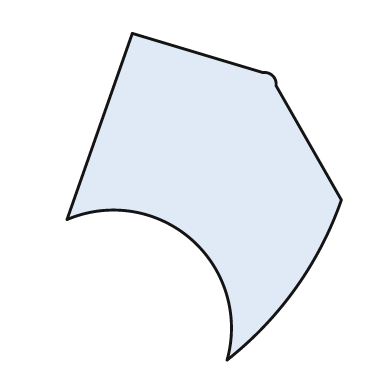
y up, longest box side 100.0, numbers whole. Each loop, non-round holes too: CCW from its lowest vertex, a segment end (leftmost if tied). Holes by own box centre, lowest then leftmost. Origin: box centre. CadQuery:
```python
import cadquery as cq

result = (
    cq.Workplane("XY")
    .moveTo(7.0, -50.0)
    .threePointArc((28.0, -28.0), (42.0, -1.0))
    .lineTo(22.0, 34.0)
    .threePointArc((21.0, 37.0), (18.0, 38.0))
    .lineTo(-22.0, 50.0)
    .lineTo(-42.0, -7.0)
    .threePointArc((-4.0, -13.0), (7.0, -50.0))
    .close()
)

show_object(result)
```